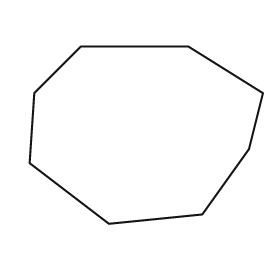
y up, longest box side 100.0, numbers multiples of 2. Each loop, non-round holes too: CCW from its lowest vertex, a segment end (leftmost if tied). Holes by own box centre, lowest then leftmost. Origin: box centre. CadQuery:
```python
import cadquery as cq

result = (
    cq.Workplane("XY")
    .moveTo(-16.0, -38.0)
    .lineTo(24.0, -34.0)
    .lineTo(44.0, -6.0)
    .lineTo(50.0, 18.0)
    .lineTo(18.0, 38.0)
    .lineTo(-28.0, 38.0)
    .lineTo(-48.0, 18.0)
    .lineTo(-50.0, -12.0)
    .close()
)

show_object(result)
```